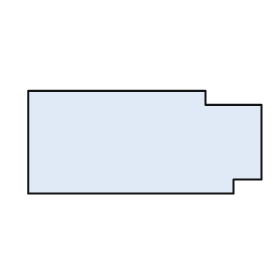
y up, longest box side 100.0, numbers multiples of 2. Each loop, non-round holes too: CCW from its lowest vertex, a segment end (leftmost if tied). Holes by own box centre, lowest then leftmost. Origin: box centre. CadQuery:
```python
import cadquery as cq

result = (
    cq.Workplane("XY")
    .moveTo(-50.0, -22.0)
    .lineTo(38.0, -22.0)
    .lineTo(38.0, -16.0)
    .lineTo(50.0, -16.0)
    .lineTo(50.0, 16.0)
    .lineTo(26.0, 16.0)
    .lineTo(26.0, 22.0)
    .lineTo(-50.0, 22.0)
    .close()
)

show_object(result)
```